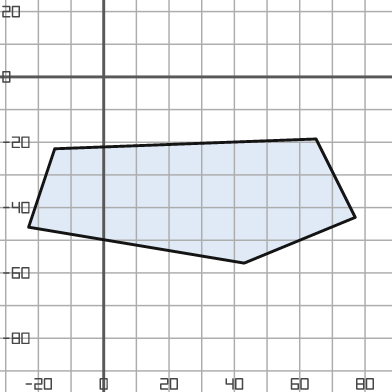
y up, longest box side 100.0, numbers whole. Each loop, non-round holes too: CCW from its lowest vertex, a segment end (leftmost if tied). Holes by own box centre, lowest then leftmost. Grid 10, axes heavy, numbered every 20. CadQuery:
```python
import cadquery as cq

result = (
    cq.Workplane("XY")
    .moveTo(43.0, -57.0)
    .lineTo(77.0, -43.0)
    .lineTo(65.0, -19.0)
    .lineTo(-15.0, -22.0)
    .lineTo(-23.0, -46.0)
    .close()
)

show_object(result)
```